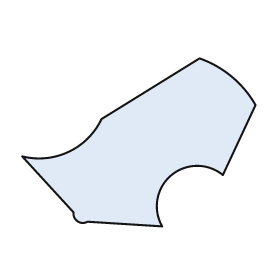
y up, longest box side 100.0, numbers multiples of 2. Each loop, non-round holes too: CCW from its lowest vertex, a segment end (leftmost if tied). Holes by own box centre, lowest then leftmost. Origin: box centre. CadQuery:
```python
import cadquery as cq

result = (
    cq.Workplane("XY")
    .moveTo(10.0, -36.0)
    .threePointArc((14.0, -14.0), (36.0, -14.0))
    .lineTo(50.0, 16.0)
    .threePointArc((40.0, 28.0), (26.0, 36.0))
    .lineTo(-16.0, 10.0)
    .threePointArc((-30.0, -4.0), (-50.0, -6.0))
    .lineTo(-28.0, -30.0)
    .threePointArc((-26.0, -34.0), (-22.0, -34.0))
    .close()
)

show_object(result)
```